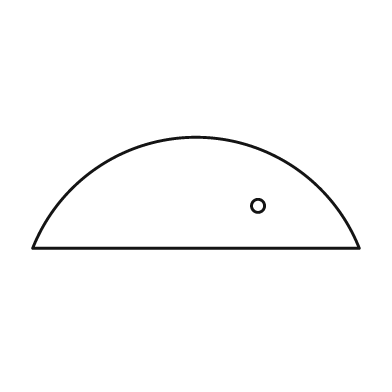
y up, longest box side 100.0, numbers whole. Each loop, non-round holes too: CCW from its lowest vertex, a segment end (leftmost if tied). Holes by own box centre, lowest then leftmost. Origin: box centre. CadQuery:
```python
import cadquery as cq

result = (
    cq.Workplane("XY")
    .moveTo(-50.0, -17.0)
    .lineTo(50.0, -17.0)
    .threePointArc((0.0, 17.0), (-50.0, -17.0))
    .close()
    .moveTo(19.0, -4.0)
    .circle(2.0)
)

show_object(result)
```